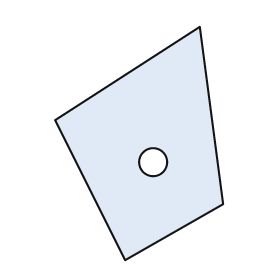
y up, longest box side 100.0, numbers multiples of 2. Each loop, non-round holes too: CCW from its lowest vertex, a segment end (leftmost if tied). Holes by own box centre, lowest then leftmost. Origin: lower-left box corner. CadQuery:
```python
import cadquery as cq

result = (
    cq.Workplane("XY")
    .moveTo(30.0, 0.0)
    .lineTo(72.0, 24.0)
    .lineTo(62.0, 100.0)
    .lineTo(0.0, 60.0)
    .close()
    .moveTo(42.0, 42.0)
    .circle(6.0)
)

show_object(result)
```